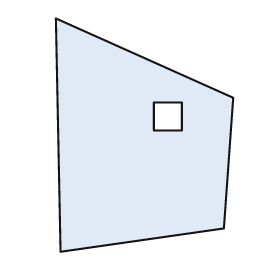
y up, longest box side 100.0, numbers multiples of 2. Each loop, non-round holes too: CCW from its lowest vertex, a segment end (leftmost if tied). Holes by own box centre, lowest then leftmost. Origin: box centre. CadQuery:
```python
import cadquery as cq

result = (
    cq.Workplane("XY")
    .moveTo(-36.0, -50.0)
    .lineTo(34.0, -40.0)
    .lineTo(38.0, 16.0)
    .lineTo(-38.0, 50.0)
    .close()
    .moveTo(4.0, 2.0)
    .lineTo(16.0, 2.0)
    .lineTo(16.0, 14.0)
    .lineTo(4.0, 14.0)
    .close()
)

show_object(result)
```